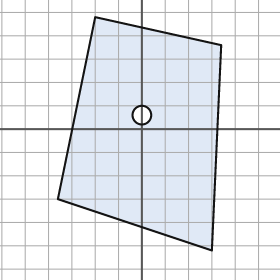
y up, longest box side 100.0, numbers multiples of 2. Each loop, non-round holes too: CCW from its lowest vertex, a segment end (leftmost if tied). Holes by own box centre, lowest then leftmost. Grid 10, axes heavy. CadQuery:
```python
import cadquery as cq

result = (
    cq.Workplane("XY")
    .moveTo(30.0, -52.0)
    .lineTo(34.0, 36.0)
    .lineTo(-20.0, 48.0)
    .lineTo(-36.0, -30.0)
    .close()
    .moveTo(0.0, 6.0)
    .circle(4.0)
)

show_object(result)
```